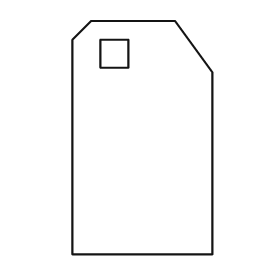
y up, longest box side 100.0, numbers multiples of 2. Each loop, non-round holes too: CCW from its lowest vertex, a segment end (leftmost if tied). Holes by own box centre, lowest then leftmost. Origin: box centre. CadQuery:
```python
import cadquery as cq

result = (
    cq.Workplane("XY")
    .moveTo(-30.0, -50.0)
    .lineTo(30.0, -50.0)
    .lineTo(30.0, 28.0)
    .lineTo(14.0, 50.0)
    .lineTo(-22.0, 50.0)
    .lineTo(-30.0, 42.0)
    .close()
    .moveTo(-18.0, 30.0)
    .lineTo(-6.0, 30.0)
    .lineTo(-6.0, 42.0)
    .lineTo(-18.0, 42.0)
    .close()
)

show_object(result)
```